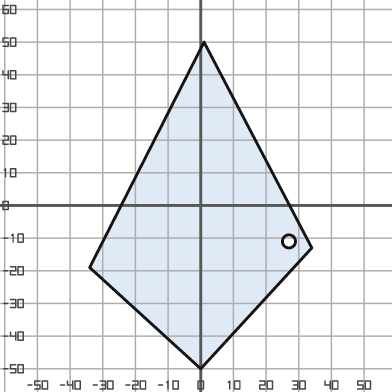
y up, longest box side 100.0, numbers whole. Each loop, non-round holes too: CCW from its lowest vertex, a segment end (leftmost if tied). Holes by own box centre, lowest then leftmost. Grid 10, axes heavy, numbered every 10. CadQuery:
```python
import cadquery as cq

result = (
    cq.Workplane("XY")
    .moveTo(0.0, -50.0)
    .lineTo(34.0, -13.0)
    .lineTo(1.0, 50.0)
    .lineTo(-34.0, -19.0)
    .close()
    .moveTo(27.0, -11.0)
    .circle(2.0)
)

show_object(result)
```